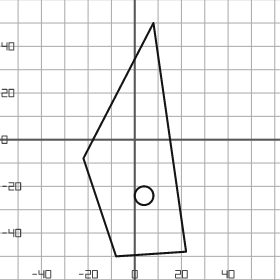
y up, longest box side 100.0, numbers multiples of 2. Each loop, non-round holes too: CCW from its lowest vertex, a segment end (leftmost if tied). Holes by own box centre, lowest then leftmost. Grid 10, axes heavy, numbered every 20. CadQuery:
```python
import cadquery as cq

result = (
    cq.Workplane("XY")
    .moveTo(-8.0, -50.0)
    .lineTo(22.0, -48.0)
    .lineTo(8.0, 50.0)
    .lineTo(-22.0, -8.0)
    .close()
    .moveTo(4.0, -24.0)
    .circle(4.0)
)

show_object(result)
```